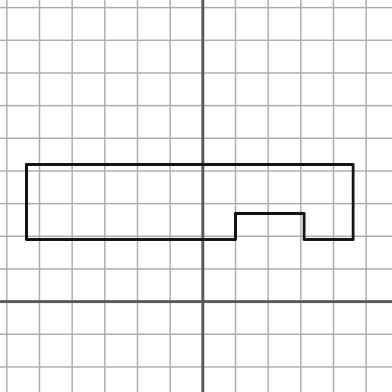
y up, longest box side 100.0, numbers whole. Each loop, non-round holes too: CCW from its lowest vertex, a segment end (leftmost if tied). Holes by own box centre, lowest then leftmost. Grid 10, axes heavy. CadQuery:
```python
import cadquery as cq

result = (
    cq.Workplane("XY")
    .moveTo(-54.0, 19.0)
    .lineTo(10.0, 19.0)
    .lineTo(10.0, 27.0)
    .lineTo(31.0, 27.0)
    .lineTo(31.0, 19.0)
    .lineTo(46.0, 19.0)
    .lineTo(46.0, 42.0)
    .lineTo(-54.0, 42.0)
    .close()
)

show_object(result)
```